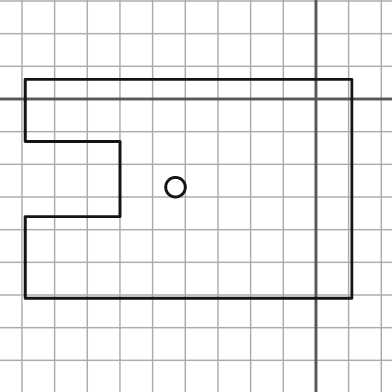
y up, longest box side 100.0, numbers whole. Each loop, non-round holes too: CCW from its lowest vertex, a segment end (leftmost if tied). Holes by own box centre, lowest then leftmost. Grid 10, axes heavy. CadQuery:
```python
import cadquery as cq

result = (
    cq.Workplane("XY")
    .moveTo(-89.0, -61.0)
    .lineTo(11.0, -61.0)
    .lineTo(11.0, 6.0)
    .lineTo(-89.0, 6.0)
    .lineTo(-89.0, -13.0)
    .lineTo(-60.0, -13.0)
    .lineTo(-60.0, -36.0)
    .lineTo(-89.0, -36.0)
    .close()
    .moveTo(-43.0, -27.0)
    .circle(3.0)
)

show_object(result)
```